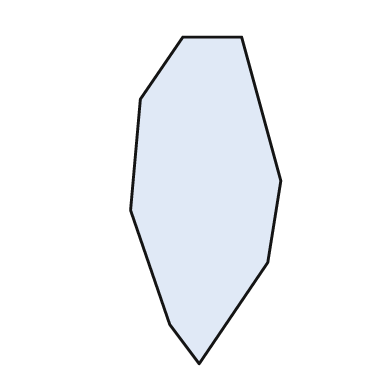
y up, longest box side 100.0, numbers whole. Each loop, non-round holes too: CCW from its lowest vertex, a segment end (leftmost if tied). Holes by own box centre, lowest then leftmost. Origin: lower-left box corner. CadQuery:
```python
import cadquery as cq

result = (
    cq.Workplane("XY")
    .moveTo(21.0, 0.0)
    .lineTo(42.0, 31.0)
    .lineTo(46.0, 56.0)
    .lineTo(34.0, 100.0)
    .lineTo(16.0, 100.0)
    .lineTo(3.0, 81.0)
    .lineTo(0.0, 47.0)
    .lineTo(12.0, 12.0)
    .close()
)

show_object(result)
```